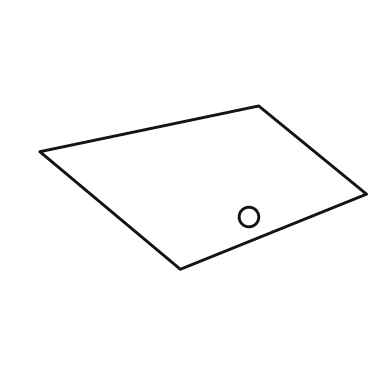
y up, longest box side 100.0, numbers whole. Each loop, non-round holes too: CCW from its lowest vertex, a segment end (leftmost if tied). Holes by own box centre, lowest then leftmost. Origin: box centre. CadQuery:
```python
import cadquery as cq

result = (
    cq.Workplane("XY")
    .moveTo(-7.0, -25.0)
    .lineTo(50.0, -2.0)
    .lineTo(17.0, 25.0)
    .lineTo(-50.0, 11.0)
    .close()
    .moveTo(14.0, -9.0)
    .circle(3.0)
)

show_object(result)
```